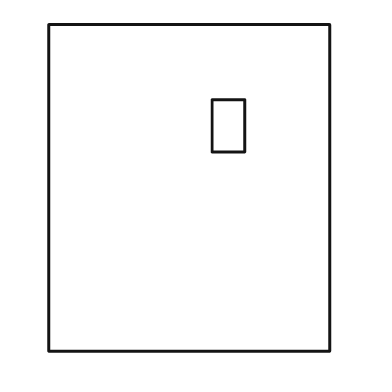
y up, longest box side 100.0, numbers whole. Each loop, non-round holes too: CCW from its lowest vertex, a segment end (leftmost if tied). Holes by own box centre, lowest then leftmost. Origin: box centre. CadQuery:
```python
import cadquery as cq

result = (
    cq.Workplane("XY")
    .moveTo(-43.0, -50.0)
    .lineTo(43.0, -50.0)
    .lineTo(43.0, 50.0)
    .lineTo(-43.0, 50.0)
    .close()
    .moveTo(7.0, 11.0)
    .lineTo(17.0, 11.0)
    .lineTo(17.0, 27.0)
    .lineTo(7.0, 27.0)
    .close()
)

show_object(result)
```